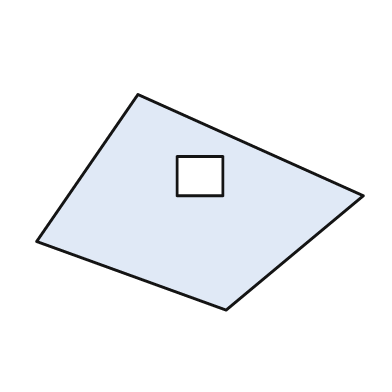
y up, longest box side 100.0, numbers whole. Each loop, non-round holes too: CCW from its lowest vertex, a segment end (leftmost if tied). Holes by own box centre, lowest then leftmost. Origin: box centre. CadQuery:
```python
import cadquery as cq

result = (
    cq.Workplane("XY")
    .moveTo(8.0, -33.0)
    .lineTo(50.0, 2.0)
    .lineTo(-19.0, 33.0)
    .lineTo(-50.0, -12.0)
    .close()
    .moveTo(-7.0, 2.0)
    .lineTo(7.0, 2.0)
    .lineTo(7.0, 14.0)
    .lineTo(-7.0, 14.0)
    .close()
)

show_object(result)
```